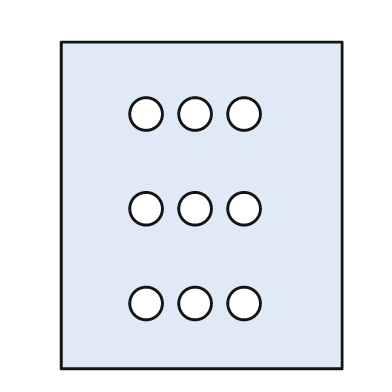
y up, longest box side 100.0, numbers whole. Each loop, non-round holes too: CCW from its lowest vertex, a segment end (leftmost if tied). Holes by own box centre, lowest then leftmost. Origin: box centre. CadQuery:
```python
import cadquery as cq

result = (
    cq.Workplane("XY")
    .moveTo(-43.0, -50.0)
    .lineTo(43.0, -50.0)
    .lineTo(43.0, 50.0)
    .lineTo(-43.0, 50.0)
    .close()
    .moveTo(-17.0, -30.0)
    .circle(5.0)
    .moveTo(-2.0, -30.0)
    .circle(5.0)
    .moveTo(13.0, -30.0)
    .circle(5.0)
    .moveTo(-17.0, -1.0)
    .circle(5.0)
    .moveTo(-2.0, -1.0)
    .circle(5.0)
    .moveTo(13.0, -1.0)
    .circle(5.0)
    .moveTo(-17.0, 28.0)
    .circle(5.0)
    .moveTo(-2.0, 28.0)
    .circle(5.0)
    .moveTo(13.0, 28.0)
    .circle(5.0)
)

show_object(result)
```